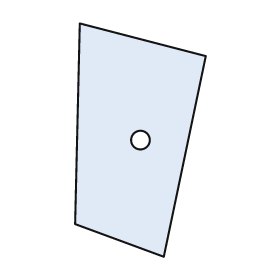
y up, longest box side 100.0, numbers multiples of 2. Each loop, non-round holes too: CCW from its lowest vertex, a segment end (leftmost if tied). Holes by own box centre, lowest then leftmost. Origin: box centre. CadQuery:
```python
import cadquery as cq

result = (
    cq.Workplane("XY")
    .moveTo(10.0, -50.0)
    .lineTo(28.0, 36.0)
    .lineTo(-26.0, 50.0)
    .lineTo(-28.0, -36.0)
    .close()
    .moveTo(0.0, 0.0)
    .circle(4.0)
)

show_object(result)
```